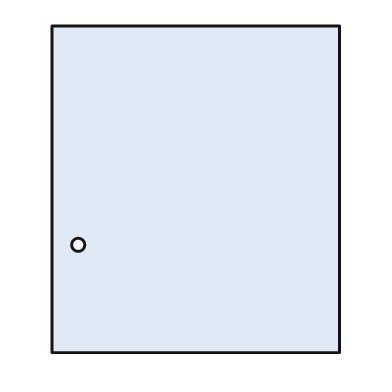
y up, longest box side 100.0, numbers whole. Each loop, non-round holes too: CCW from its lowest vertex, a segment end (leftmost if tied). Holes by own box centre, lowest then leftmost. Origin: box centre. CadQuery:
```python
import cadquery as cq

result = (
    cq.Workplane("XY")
    .moveTo(-44.0, -50.0)
    .lineTo(44.0, -50.0)
    .lineTo(44.0, 50.0)
    .lineTo(-44.0, 50.0)
    .close()
    .moveTo(-36.0, -17.0)
    .circle(2.0)
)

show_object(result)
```